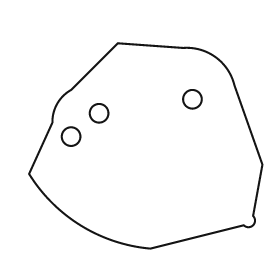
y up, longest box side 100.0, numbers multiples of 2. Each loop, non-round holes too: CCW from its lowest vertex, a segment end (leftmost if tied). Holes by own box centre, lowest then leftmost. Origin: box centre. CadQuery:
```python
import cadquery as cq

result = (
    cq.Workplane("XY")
    .moveTo(2.0, -44.0)
    .lineTo(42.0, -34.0)
    .threePointArc((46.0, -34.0), (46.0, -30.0))
    .lineTo(50.0, -8.0)
    .lineTo(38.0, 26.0)
    .threePointArc((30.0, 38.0), (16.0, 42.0))
    .lineTo(-12.0, 44.0)
    .lineTo(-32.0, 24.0)
    .threePointArc((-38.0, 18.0), (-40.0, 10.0))
    .lineTo(-50.0, -12.0)
    .threePointArc((-28.0, -34.0), (2.0, -44.0))
    .close()
    .moveTo(-32.0, 4.0)
    .circle(4.0)
    .moveTo(-20.0, 14.0)
    .circle(4.0)
    .moveTo(20.0, 20.0)
    .circle(4.0)
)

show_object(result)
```